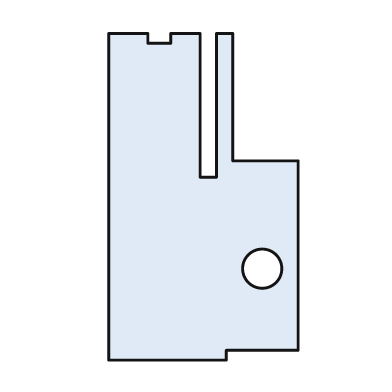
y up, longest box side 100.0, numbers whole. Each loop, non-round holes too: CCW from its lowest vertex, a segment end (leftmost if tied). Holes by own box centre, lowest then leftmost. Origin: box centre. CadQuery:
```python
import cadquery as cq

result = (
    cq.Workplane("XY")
    .moveTo(-29.0, -50.0)
    .lineTo(7.0, -50.0)
    .lineTo(7.0, -47.0)
    .lineTo(29.0, -47.0)
    .lineTo(29.0, 11.0)
    .lineTo(9.0, 11.0)
    .lineTo(9.0, 50.0)
    .lineTo(4.0, 50.0)
    .lineTo(4.0, 6.0)
    .lineTo(-1.0, 6.0)
    .lineTo(-1.0, 50.0)
    .lineTo(-10.0, 50.0)
    .lineTo(-10.0, 47.0)
    .lineTo(-17.0, 47.0)
    .lineTo(-17.0, 50.0)
    .lineTo(-29.0, 50.0)
    .close()
    .moveTo(18.0, -22.0)
    .circle(6.0)
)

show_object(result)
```